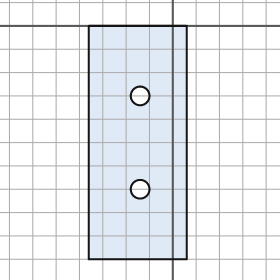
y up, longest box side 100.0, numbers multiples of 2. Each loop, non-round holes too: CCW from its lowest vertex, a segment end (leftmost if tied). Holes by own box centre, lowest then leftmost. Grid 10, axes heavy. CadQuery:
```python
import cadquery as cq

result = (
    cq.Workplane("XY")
    .moveTo(-36.0, -100.0)
    .lineTo(6.0, -100.0)
    .lineTo(6.0, 0.0)
    .lineTo(-36.0, 0.0)
    .close()
    .moveTo(-14.0, -70.0)
    .circle(4.0)
    .moveTo(-14.0, -30.0)
    .circle(4.0)
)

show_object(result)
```